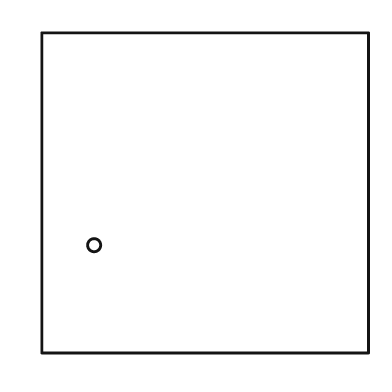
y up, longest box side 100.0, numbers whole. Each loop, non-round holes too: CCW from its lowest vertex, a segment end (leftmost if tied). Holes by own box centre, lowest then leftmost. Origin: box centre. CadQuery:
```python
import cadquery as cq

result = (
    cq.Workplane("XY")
    .moveTo(-50.0, -49.0)
    .lineTo(50.0, -49.0)
    .lineTo(50.0, 49.0)
    .lineTo(-50.0, 49.0)
    .close()
    .moveTo(-34.0, -16.0)
    .circle(2.0)
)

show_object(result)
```